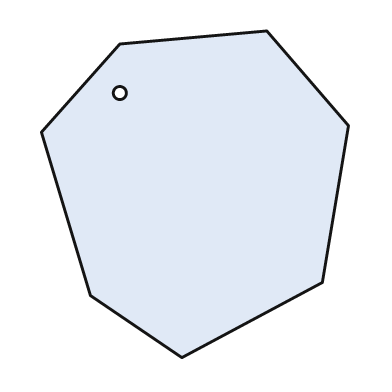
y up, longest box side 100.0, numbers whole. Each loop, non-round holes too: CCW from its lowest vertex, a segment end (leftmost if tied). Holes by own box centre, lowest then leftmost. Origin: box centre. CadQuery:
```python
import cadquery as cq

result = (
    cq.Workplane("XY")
    .moveTo(-4.0, -50.0)
    .lineTo(39.0, -27.0)
    .lineTo(47.0, 21.0)
    .lineTo(22.0, 50.0)
    .lineTo(-23.0, 46.0)
    .lineTo(-47.0, 19.0)
    .lineTo(-32.0, -31.0)
    .close()
    .moveTo(-23.0, 31.0)
    .circle(2.0)
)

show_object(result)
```